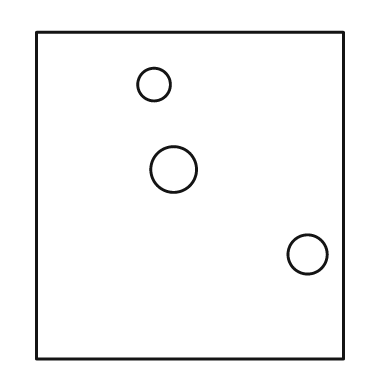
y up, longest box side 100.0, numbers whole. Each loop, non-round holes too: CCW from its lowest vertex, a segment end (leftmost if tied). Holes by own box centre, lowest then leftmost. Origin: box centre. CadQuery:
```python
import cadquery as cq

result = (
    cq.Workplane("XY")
    .moveTo(-47.0, -50.0)
    .lineTo(47.0, -50.0)
    .lineTo(47.0, 50.0)
    .lineTo(-47.0, 50.0)
    .close()
    .moveTo(36.0, -18.0)
    .circle(6.0)
    .moveTo(-5.0, 8.0)
    .circle(7.0)
    .moveTo(-11.0, 34.0)
    .circle(5.0)
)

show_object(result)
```